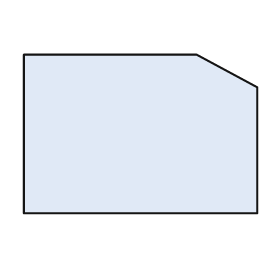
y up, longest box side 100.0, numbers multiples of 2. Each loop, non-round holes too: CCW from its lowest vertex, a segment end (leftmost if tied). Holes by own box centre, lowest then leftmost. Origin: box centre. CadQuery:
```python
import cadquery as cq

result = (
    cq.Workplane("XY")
    .moveTo(-50.0, -34.0)
    .lineTo(50.0, -34.0)
    .lineTo(50.0, 20.0)
    .lineTo(24.0, 34.0)
    .lineTo(-50.0, 34.0)
    .close()
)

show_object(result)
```